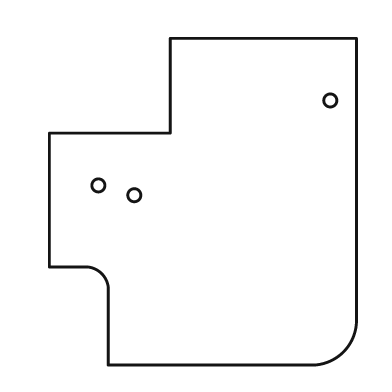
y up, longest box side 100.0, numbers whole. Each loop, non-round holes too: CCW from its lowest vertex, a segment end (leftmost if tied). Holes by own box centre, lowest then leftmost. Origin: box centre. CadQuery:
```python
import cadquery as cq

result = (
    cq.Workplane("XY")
    .moveTo(-29.0, -50.0)
    .lineTo(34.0, -50.0)
    .threePointArc((43.0, -46.0), (47.0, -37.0))
    .lineTo(47.0, 50.0)
    .lineTo(-10.0, 50.0)
    .lineTo(-10.0, 21.0)
    .lineTo(-47.0, 21.0)
    .lineTo(-47.0, -20.0)
    .lineTo(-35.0, -20.0)
    .threePointArc((-31.0, -22.0), (-29.0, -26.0))
    .close()
    .moveTo(-21.0, 2.0)
    .circle(2.0)
    .moveTo(-32.0, 5.0)
    .circle(2.0)
    .moveTo(39.0, 31.0)
    .circle(2.0)
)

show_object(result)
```